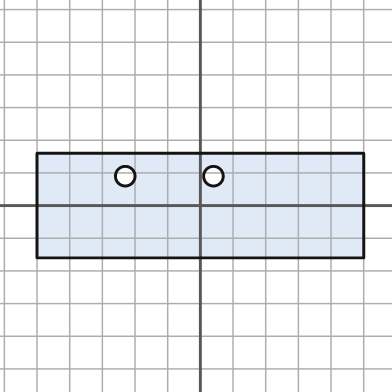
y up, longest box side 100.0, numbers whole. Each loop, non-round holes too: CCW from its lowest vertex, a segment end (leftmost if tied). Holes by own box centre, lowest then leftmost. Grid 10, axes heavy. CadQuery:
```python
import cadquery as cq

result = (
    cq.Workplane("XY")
    .moveTo(-50.0, -16.0)
    .lineTo(50.0, -16.0)
    .lineTo(50.0, 16.0)
    .lineTo(-50.0, 16.0)
    .close()
    .moveTo(-23.0, 9.0)
    .circle(3.0)
    .moveTo(4.0, 9.0)
    .circle(3.0)
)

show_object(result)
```